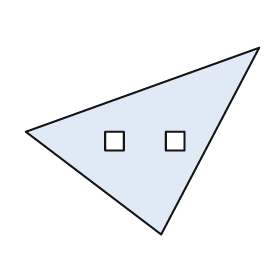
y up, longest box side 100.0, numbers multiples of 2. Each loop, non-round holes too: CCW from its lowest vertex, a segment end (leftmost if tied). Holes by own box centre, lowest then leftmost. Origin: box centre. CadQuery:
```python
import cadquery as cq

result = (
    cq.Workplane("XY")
    .moveTo(8.0, -40.0)
    .lineTo(50.0, 40.0)
    .lineTo(-50.0, 4.0)
    .close()
    .moveTo(-16.0, -4.0)
    .lineTo(-8.0, -4.0)
    .lineTo(-8.0, 4.0)
    .lineTo(-16.0, 4.0)
    .close()
    .moveTo(10.0, -4.0)
    .lineTo(18.0, -4.0)
    .lineTo(18.0, 4.0)
    .lineTo(10.0, 4.0)
    .close()
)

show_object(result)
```